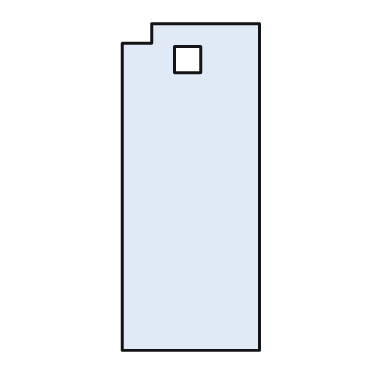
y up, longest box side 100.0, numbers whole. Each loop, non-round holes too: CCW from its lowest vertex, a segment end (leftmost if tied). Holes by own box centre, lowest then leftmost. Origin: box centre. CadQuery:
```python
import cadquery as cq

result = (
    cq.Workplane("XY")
    .moveTo(-21.0, -50.0)
    .lineTo(21.0, -50.0)
    .lineTo(21.0, 50.0)
    .lineTo(-12.0, 50.0)
    .lineTo(-12.0, 44.0)
    .lineTo(-21.0, 44.0)
    .close()
    .moveTo(-5.0, 35.0)
    .lineTo(3.0, 35.0)
    .lineTo(3.0, 43.0)
    .lineTo(-5.0, 43.0)
    .close()
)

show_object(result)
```